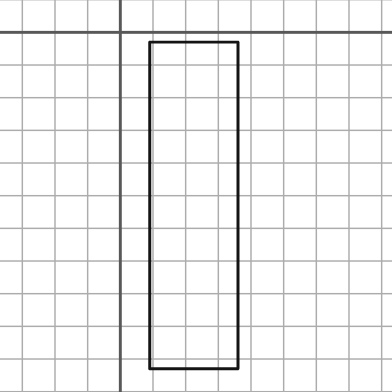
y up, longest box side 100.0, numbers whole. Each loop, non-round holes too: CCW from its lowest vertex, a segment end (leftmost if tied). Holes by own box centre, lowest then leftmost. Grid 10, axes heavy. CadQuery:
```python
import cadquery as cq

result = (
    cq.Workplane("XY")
    .moveTo(9.0, -103.0)
    .lineTo(36.0, -103.0)
    .lineTo(36.0, -3.0)
    .lineTo(9.0, -3.0)
    .close()
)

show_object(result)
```